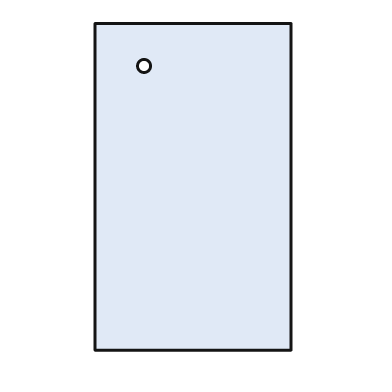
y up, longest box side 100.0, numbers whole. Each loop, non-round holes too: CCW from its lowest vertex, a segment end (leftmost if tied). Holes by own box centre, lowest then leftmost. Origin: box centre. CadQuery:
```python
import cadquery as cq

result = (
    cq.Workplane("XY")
    .moveTo(-30.0, -50.0)
    .lineTo(30.0, -50.0)
    .lineTo(30.0, 50.0)
    .lineTo(-30.0, 50.0)
    .close()
    .moveTo(-15.0, 37.0)
    .circle(2.0)
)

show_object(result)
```